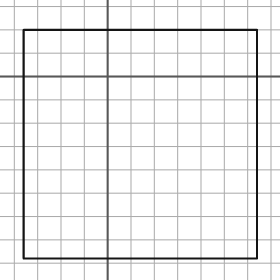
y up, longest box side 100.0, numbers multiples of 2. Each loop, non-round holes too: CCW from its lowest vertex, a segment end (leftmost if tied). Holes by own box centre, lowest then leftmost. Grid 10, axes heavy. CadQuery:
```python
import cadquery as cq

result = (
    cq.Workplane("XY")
    .moveTo(-36.0, -78.0)
    .lineTo(64.0, -78.0)
    .lineTo(64.0, 20.0)
    .lineTo(-36.0, 20.0)
    .close()
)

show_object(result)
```